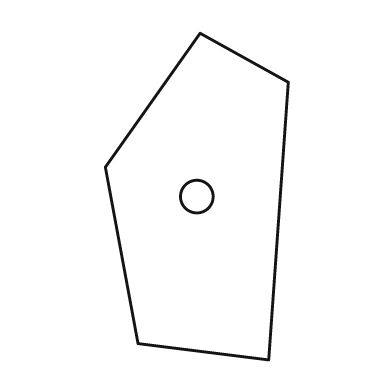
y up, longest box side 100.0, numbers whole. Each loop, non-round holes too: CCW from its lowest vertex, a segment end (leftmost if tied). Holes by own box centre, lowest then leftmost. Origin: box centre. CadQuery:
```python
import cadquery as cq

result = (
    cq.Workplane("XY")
    .moveTo(22.0, -50.0)
    .lineTo(28.0, 35.0)
    .lineTo(1.0, 50.0)
    .lineTo(-28.0, 9.0)
    .lineTo(-18.0, -45.0)
    .close()
    .moveTo(0.0, 0.0)
    .circle(5.0)
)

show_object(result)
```